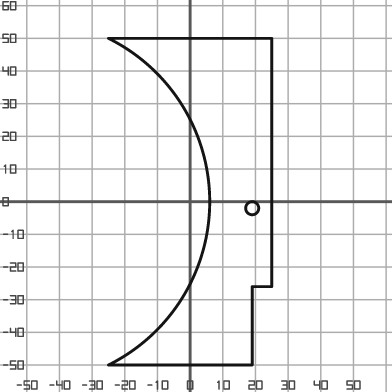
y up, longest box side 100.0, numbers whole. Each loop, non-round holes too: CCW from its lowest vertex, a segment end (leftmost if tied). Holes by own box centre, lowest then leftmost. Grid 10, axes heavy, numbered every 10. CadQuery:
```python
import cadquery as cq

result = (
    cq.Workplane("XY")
    .moveTo(-25.0, -50.0)
    .lineTo(19.0, -50.0)
    .lineTo(19.0, -26.0)
    .lineTo(25.0, -26.0)
    .lineTo(25.0, 50.0)
    .lineTo(-25.0, 50.0)
    .threePointArc((6.0, 0.0), (-25.0, -50.0))
    .close()
    .moveTo(19.0, -2.0)
    .circle(2.0)
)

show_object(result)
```